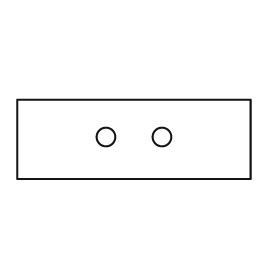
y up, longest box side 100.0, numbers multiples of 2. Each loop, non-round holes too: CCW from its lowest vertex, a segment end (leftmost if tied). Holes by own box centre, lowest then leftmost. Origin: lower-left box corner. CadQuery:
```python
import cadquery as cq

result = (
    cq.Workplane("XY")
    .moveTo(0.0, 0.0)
    .lineTo(100.0, 0.0)
    .lineTo(100.0, 34.0)
    .lineTo(0.0, 34.0)
    .close()
    .moveTo(38.0, 18.0)
    .circle(4.0)
    .moveTo(62.0, 18.0)
    .circle(4.0)
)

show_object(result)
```